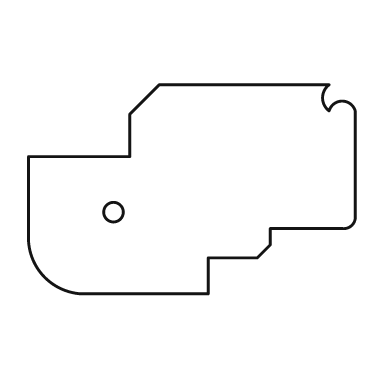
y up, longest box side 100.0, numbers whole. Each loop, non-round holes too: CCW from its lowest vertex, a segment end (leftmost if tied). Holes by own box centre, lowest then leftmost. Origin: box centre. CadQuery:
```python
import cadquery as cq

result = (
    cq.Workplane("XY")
    .moveTo(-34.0, -32.0)
    .lineTo(5.0, -32.0)
    .lineTo(5.0, -21.0)
    .lineTo(20.0, -21.0)
    .lineTo(24.0, -17.0)
    .lineTo(24.0, -12.0)
    .lineTo(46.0, -12.0)
    .threePointArc((49.0, -11.0), (50.0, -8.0))
    .lineTo(50.0, 24.0)
    .threePointArc((46.0, 27.0), (42.0, 24.0))
    .threePointArc((40.0, 28.0), (42.0, 32.0))
    .lineTo(-10.0, 32.0)
    .lineTo(-19.0, 23.0)
    .lineTo(-19.0, 10.0)
    .lineTo(-50.0, 10.0)
    .lineTo(-50.0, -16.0)
    .threePointArc((-45.0, -27.0), (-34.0, -32.0))
    .close()
    .moveTo(-24.0, -7.0)
    .circle(3.0)
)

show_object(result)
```